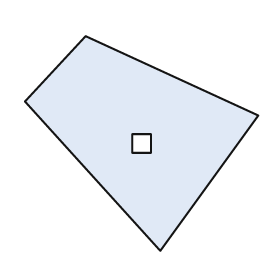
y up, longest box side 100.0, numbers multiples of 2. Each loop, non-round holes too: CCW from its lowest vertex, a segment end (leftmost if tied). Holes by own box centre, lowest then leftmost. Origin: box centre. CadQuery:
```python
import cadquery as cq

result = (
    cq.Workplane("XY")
    .moveTo(8.0, -46.0)
    .lineTo(50.0, 12.0)
    .lineTo(-24.0, 46.0)
    .lineTo(-50.0, 18.0)
    .close()
    .moveTo(-4.0, -4.0)
    .lineTo(4.0, -4.0)
    .lineTo(4.0, 4.0)
    .lineTo(-4.0, 4.0)
    .close()
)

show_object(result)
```